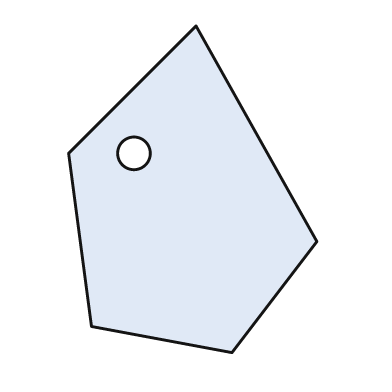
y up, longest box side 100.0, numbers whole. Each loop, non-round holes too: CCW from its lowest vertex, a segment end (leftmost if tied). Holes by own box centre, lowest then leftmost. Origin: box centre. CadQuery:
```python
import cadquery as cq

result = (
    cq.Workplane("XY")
    .moveTo(12.0, -50.0)
    .lineTo(38.0, -16.0)
    .lineTo(1.0, 50.0)
    .lineTo(-38.0, 11.0)
    .lineTo(-31.0, -42.0)
    .close()
    .moveTo(-18.0, 11.0)
    .circle(5.0)
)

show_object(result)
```